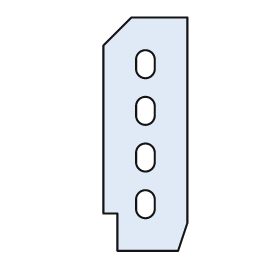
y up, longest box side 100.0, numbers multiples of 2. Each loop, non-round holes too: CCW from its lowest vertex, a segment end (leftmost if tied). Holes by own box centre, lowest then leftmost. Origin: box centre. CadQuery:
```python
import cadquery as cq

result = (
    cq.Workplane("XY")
    .moveTo(-12.0, -50.0)
    .lineTo(14.0, -50.0)
    .lineTo(18.0, -38.0)
    .lineTo(18.0, 50.0)
    .lineTo(-6.0, 50.0)
    .lineTo(-18.0, 38.0)
    .lineTo(-18.0, -34.0)
    .lineTo(-12.0, -34.0)
    .close()
    .moveTo(-4.0, -32.0)
    .threePointArc((0.0, -36.0), (4.0, -32.0))
    .lineTo(4.0, -28.0)
    .threePointArc((0.0, -24.0), (-4.0, -28.0))
    .close()
    .moveTo(-4.0, -12.0)
    .threePointArc((0.0, -16.0), (4.0, -12.0))
    .lineTo(4.0, -8.0)
    .threePointArc((0.0, -4.0), (-4.0, -8.0))
    .close()
    .moveTo(-4.0, 8.0)
    .threePointArc((0.0, 4.0), (4.0, 8.0))
    .lineTo(4.0, 12.0)
    .threePointArc((0.0, 16.0), (-4.0, 12.0))
    .close()
    .moveTo(-4.0, 28.0)
    .threePointArc((0.0, 24.0), (4.0, 28.0))
    .lineTo(4.0, 32.0)
    .threePointArc((0.0, 36.0), (-4.0, 32.0))
    .close()
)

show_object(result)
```